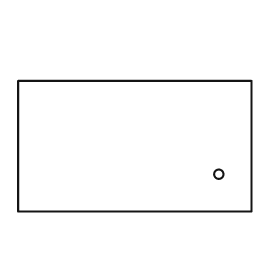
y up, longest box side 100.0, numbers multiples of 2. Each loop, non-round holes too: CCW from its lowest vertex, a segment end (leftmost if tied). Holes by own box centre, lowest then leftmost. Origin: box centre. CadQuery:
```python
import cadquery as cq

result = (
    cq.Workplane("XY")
    .moveTo(-50.0, -28.0)
    .lineTo(50.0, -28.0)
    .lineTo(50.0, 28.0)
    .lineTo(-50.0, 28.0)
    .close()
    .moveTo(36.0, -12.0)
    .circle(2.0)
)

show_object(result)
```